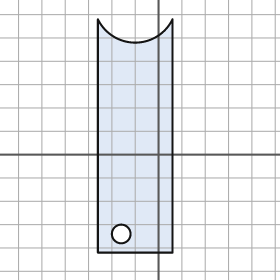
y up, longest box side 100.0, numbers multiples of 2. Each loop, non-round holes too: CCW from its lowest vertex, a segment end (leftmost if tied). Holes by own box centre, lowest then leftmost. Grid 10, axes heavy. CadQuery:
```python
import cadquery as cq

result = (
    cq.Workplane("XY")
    .moveTo(-26.0, -42.0)
    .lineTo(6.0, -42.0)
    .lineTo(6.0, 58.0)
    .threePointArc((-10.0, 48.0), (-26.0, 58.0))
    .close()
    .moveTo(-16.0, -34.0)
    .circle(4.0)
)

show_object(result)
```